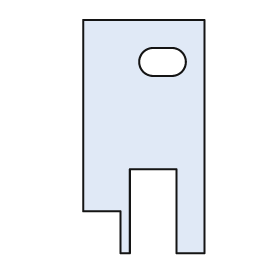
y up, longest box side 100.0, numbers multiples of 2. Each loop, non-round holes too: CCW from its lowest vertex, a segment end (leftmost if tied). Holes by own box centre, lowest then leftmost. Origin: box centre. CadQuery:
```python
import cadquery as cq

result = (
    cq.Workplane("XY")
    .moveTo(-10.0, -50.0)
    .lineTo(-6.0, -50.0)
    .lineTo(-6.0, -14.0)
    .lineTo(14.0, -14.0)
    .lineTo(14.0, -50.0)
    .lineTo(26.0, -50.0)
    .lineTo(26.0, 50.0)
    .lineTo(-26.0, 50.0)
    .lineTo(-26.0, -32.0)
    .lineTo(-10.0, -32.0)
    .close()
    .moveTo(4.0, 26.0)
    .lineTo(12.0, 26.0)
    .threePointArc((18.0, 32.0), (12.0, 38.0))
    .lineTo(4.0, 38.0)
    .threePointArc((-2.0, 32.0), (4.0, 26.0))
    .close()
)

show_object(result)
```